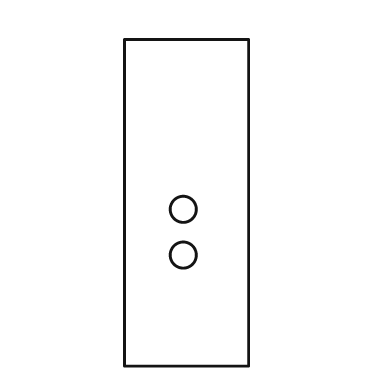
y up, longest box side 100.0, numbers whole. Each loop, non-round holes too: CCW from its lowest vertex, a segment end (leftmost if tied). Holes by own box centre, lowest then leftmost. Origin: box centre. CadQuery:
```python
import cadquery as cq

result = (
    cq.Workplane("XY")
    .moveTo(-19.0, -50.0)
    .lineTo(19.0, -50.0)
    .lineTo(19.0, 50.0)
    .lineTo(-19.0, 50.0)
    .close()
    .moveTo(-1.0, -16.0)
    .circle(4.0)
    .moveTo(-1.0, -2.0)
    .circle(4.0)
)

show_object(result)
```